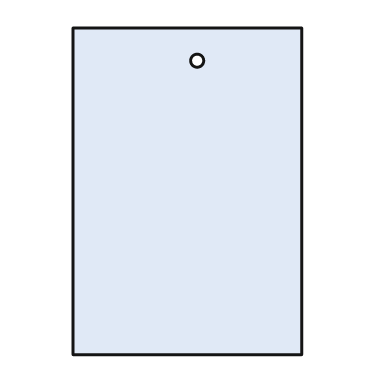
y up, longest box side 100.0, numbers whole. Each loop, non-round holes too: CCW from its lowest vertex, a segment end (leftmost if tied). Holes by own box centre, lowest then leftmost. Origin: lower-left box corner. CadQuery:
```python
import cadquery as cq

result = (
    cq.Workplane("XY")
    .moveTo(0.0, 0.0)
    .lineTo(70.0, 0.0)
    .lineTo(70.0, 100.0)
    .lineTo(0.0, 100.0)
    .close()
    .moveTo(38.0, 90.0)
    .circle(2.0)
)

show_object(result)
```